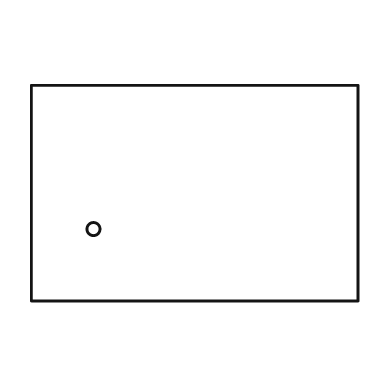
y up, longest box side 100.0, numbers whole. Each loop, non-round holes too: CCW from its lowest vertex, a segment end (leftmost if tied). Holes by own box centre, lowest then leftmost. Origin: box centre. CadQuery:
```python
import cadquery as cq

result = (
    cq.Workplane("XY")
    .moveTo(-50.0, -33.0)
    .lineTo(50.0, -33.0)
    .lineTo(50.0, 33.0)
    .lineTo(-50.0, 33.0)
    .close()
    .moveTo(-31.0, -11.0)
    .circle(2.0)
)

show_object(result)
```